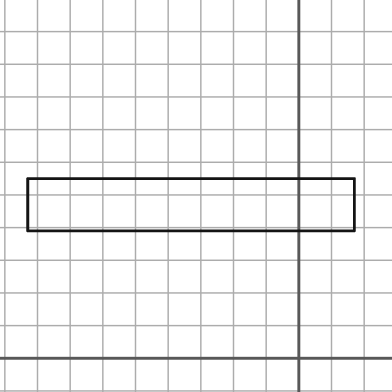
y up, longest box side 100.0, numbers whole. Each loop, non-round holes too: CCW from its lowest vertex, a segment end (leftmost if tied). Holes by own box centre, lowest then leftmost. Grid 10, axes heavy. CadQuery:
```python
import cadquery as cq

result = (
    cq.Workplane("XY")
    .moveTo(-83.0, 39.0)
    .lineTo(17.0, 39.0)
    .lineTo(17.0, 55.0)
    .lineTo(-83.0, 55.0)
    .close()
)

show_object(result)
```